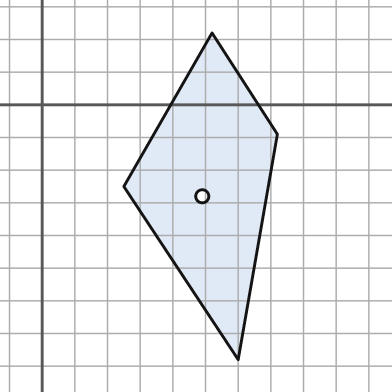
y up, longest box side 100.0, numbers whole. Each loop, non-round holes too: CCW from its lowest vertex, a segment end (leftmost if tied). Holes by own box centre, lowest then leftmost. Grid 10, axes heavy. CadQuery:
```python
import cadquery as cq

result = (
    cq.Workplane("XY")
    .moveTo(60.0, -78.0)
    .lineTo(72.0, -9.0)
    .lineTo(52.0, 22.0)
    .lineTo(25.0, -25.0)
    .close()
    .moveTo(49.0, -28.0)
    .circle(2.0)
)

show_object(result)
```